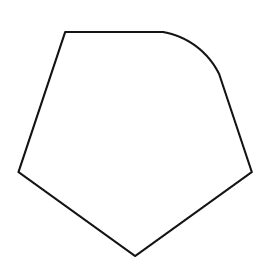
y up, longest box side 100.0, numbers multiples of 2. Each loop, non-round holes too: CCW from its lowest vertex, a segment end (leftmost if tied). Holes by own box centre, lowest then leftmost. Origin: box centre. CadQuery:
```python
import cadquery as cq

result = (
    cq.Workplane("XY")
    .moveTo(0.0, -48.0)
    .lineTo(50.0, -12.0)
    .lineTo(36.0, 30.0)
    .threePointArc((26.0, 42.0), (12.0, 48.0))
    .lineTo(-30.0, 48.0)
    .lineTo(-50.0, -12.0)
    .close()
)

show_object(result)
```